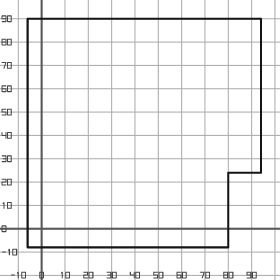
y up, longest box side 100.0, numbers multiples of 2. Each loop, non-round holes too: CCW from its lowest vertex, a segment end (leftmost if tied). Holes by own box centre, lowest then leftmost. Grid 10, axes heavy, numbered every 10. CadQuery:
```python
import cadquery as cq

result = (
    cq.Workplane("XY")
    .moveTo(-6.0, -8.0)
    .lineTo(80.0, -8.0)
    .lineTo(80.0, 24.0)
    .lineTo(94.0, 24.0)
    .lineTo(94.0, 90.0)
    .lineTo(-6.0, 90.0)
    .close()
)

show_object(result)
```